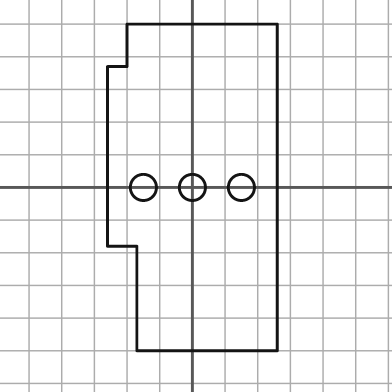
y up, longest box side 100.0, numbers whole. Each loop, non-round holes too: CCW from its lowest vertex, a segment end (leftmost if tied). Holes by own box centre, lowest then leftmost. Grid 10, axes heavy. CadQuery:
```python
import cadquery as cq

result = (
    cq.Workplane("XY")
    .moveTo(-17.0, -50.0)
    .lineTo(26.0, -50.0)
    .lineTo(26.0, 50.0)
    .lineTo(-20.0, 50.0)
    .lineTo(-20.0, 37.0)
    .lineTo(-26.0, 37.0)
    .lineTo(-26.0, -18.0)
    .lineTo(-17.0, -18.0)
    .close()
    .moveTo(-15.0, 0.0)
    .circle(4.0)
    .moveTo(0.0, 0.0)
    .circle(4.0)
    .moveTo(15.0, 0.0)
    .circle(4.0)
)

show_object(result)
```